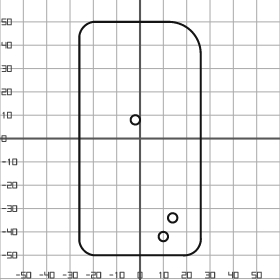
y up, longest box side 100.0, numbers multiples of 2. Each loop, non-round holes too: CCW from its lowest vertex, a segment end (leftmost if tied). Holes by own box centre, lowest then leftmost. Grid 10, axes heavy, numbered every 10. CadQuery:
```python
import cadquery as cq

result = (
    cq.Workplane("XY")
    .moveTo(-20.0, -50.0)
    .lineTo(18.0, -50.0)
    .threePointArc((24.0, -48.0), (26.0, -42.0))
    .lineTo(26.0, 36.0)
    .threePointArc((22.0, 46.0), (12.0, 50.0))
    .lineTo(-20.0, 50.0)
    .threePointArc((-24.0, 48.0), (-26.0, 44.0))
    .lineTo(-26.0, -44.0)
    .threePointArc((-24.0, -48.0), (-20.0, -50.0))
    .close()
    .moveTo(10.0, -42.0)
    .circle(2.0)
    .moveTo(14.0, -34.0)
    .circle(2.0)
    .moveTo(-2.0, 8.0)
    .circle(2.0)
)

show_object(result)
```